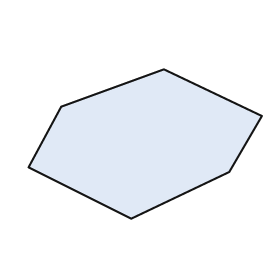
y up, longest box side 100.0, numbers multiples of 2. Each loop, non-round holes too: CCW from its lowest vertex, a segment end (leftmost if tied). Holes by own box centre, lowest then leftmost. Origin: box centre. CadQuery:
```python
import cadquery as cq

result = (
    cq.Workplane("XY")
    .moveTo(-6.0, -32.0)
    .lineTo(36.0, -12.0)
    .lineTo(50.0, 12.0)
    .lineTo(8.0, 32.0)
    .lineTo(-36.0, 16.0)
    .lineTo(-50.0, -10.0)
    .close()
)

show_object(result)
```